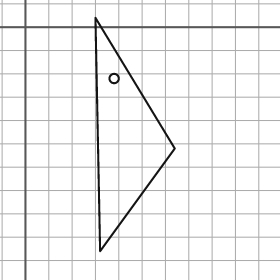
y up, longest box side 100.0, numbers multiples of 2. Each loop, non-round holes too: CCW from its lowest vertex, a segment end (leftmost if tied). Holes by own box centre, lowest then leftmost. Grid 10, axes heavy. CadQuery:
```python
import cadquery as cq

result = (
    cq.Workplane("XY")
    .moveTo(32.0, -96.0)
    .lineTo(64.0, -52.0)
    .lineTo(30.0, 4.0)
    .close()
    .moveTo(38.0, -22.0)
    .circle(2.0)
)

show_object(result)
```